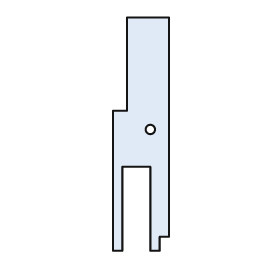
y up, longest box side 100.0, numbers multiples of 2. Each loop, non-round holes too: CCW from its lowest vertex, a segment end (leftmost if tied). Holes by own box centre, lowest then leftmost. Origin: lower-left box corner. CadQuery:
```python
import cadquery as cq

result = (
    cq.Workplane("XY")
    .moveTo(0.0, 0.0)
    .lineTo(4.0, 0.0)
    .lineTo(4.0, 36.0)
    .lineTo(16.0, 36.0)
    .lineTo(16.0, 0.0)
    .lineTo(20.0, 0.0)
    .lineTo(20.0, 6.0)
    .lineTo(24.0, 6.0)
    .lineTo(24.0, 100.0)
    .lineTo(6.0, 100.0)
    .lineTo(6.0, 60.0)
    .lineTo(0.0, 60.0)
    .close()
    .moveTo(16.0, 52.0)
    .circle(2.0)
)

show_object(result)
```